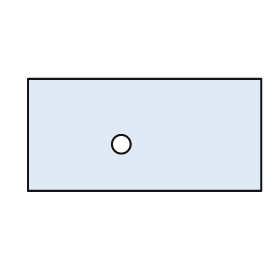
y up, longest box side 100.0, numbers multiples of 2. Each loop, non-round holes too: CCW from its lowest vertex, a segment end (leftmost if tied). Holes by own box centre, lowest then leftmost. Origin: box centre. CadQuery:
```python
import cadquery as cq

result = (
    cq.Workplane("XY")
    .moveTo(-50.0, -24.0)
    .lineTo(50.0, -24.0)
    .lineTo(50.0, 24.0)
    .lineTo(-50.0, 24.0)
    .close()
    .moveTo(-10.0, -4.0)
    .circle(4.0)
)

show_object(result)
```